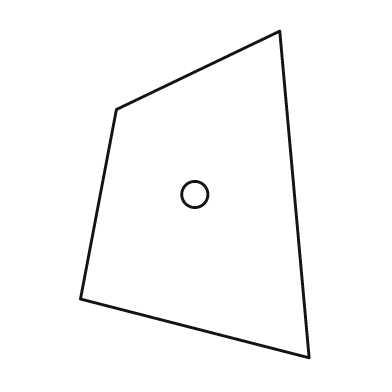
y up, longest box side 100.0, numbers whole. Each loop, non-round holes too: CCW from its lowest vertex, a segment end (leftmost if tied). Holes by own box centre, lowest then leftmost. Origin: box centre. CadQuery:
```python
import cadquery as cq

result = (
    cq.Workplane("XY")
    .moveTo(35.0, -50.0)
    .lineTo(26.0, 50.0)
    .lineTo(-24.0, 26.0)
    .lineTo(-35.0, -32.0)
    .close()
    .moveTo(0.0, 0.0)
    .circle(4.0)
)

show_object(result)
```